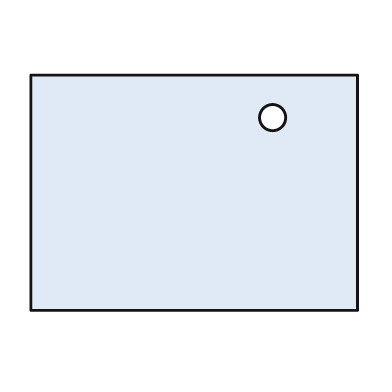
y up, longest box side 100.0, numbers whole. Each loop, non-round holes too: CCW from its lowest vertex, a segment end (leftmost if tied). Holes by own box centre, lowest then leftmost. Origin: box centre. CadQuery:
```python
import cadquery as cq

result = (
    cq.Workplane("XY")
    .moveTo(-50.0, -36.0)
    .lineTo(50.0, -36.0)
    .lineTo(50.0, 36.0)
    .lineTo(-50.0, 36.0)
    .close()
    .moveTo(24.0, 23.0)
    .circle(4.0)
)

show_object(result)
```